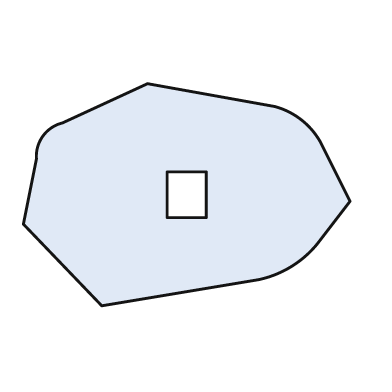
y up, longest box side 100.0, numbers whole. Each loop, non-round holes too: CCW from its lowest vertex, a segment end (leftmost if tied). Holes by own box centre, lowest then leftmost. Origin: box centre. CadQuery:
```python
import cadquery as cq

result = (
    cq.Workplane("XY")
    .moveTo(-26.0, -34.0)
    .lineTo(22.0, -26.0)
    .threePointArc((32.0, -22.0), (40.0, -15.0))
    .lineTo(50.0, -2.0)
    .lineTo(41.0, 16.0)
    .threePointArc((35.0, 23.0), (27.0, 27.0))
    .lineTo(-12.0, 34.0)
    .lineTo(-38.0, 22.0)
    .threePointArc((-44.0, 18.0), (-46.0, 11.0))
    .lineTo(-50.0, -9.0)
    .close()
    .moveTo(-6.0, -7.0)
    .lineTo(6.0, -7.0)
    .lineTo(6.0, 7.0)
    .lineTo(-6.0, 7.0)
    .close()
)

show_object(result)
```